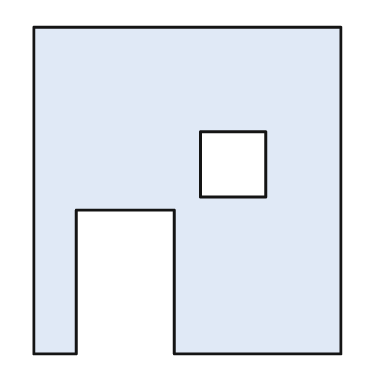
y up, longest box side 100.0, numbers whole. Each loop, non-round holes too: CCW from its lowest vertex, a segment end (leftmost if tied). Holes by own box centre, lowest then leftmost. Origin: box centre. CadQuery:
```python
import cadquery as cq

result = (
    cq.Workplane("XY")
    .moveTo(-47.0, -50.0)
    .lineTo(-34.0, -50.0)
    .lineTo(-34.0, -6.0)
    .lineTo(-4.0, -6.0)
    .lineTo(-4.0, -50.0)
    .lineTo(47.0, -50.0)
    .lineTo(47.0, 50.0)
    .lineTo(-47.0, 50.0)
    .close()
    .moveTo(4.0, -2.0)
    .lineTo(24.0, -2.0)
    .lineTo(24.0, 18.0)
    .lineTo(4.0, 18.0)
    .close()
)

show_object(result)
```